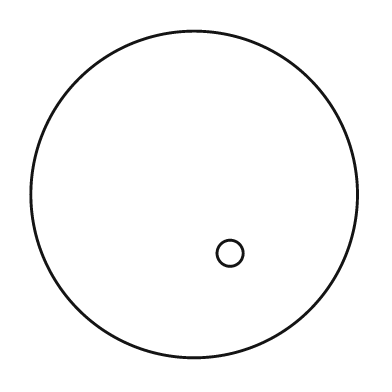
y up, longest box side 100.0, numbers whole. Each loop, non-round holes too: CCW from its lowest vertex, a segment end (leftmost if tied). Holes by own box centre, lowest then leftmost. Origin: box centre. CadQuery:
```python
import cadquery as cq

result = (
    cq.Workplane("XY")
    .moveTo(0.0, 0.0)
    .circle(50.0)
    .moveTo(11.0, -18.0)
    .circle(4.0)
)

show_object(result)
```